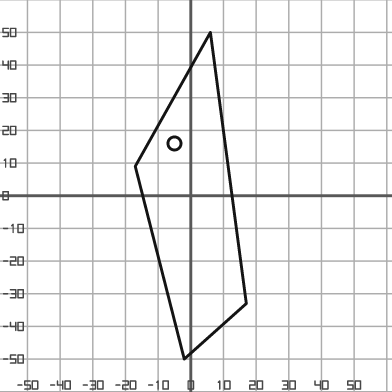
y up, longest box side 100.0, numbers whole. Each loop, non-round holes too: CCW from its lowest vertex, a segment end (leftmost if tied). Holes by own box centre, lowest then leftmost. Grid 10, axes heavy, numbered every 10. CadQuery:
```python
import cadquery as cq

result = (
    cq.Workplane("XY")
    .moveTo(-2.0, -50.0)
    .lineTo(17.0, -33.0)
    .lineTo(6.0, 50.0)
    .lineTo(-17.0, 9.0)
    .close()
    .moveTo(-5.0, 16.0)
    .circle(2.0)
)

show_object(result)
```